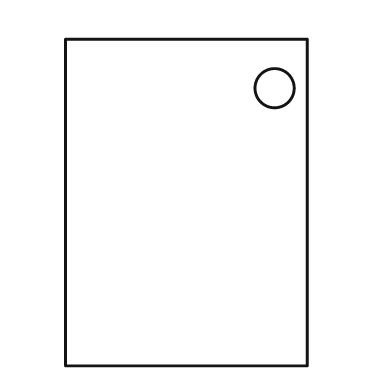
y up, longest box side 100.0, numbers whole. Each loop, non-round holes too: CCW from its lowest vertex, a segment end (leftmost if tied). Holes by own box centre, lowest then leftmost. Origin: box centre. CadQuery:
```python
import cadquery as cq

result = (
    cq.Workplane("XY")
    .moveTo(-37.0, -50.0)
    .lineTo(37.0, -50.0)
    .lineTo(37.0, 50.0)
    .lineTo(-37.0, 50.0)
    .close()
    .moveTo(27.0, 35.0)
    .circle(6.0)
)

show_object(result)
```